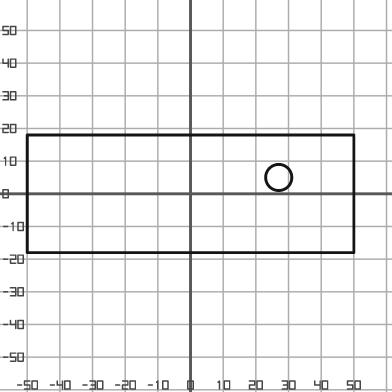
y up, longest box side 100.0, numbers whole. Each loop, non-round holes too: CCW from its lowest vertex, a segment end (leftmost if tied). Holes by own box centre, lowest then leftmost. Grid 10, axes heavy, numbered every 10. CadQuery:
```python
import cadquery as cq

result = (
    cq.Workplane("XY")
    .moveTo(-50.0, -18.0)
    .lineTo(50.0, -18.0)
    .lineTo(50.0, 18.0)
    .lineTo(-50.0, 18.0)
    .close()
    .moveTo(27.0, 5.0)
    .circle(4.0)
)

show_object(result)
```